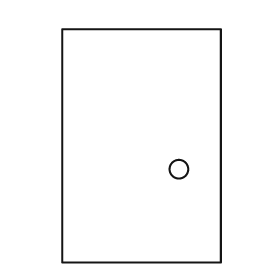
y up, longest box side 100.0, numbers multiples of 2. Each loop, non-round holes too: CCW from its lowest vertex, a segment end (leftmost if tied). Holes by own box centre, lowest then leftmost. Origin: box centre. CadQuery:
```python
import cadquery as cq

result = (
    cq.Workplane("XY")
    .moveTo(-34.0, -50.0)
    .lineTo(34.0, -50.0)
    .lineTo(34.0, 50.0)
    .lineTo(-34.0, 50.0)
    .close()
    .moveTo(16.0, -10.0)
    .circle(4.0)
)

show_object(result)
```